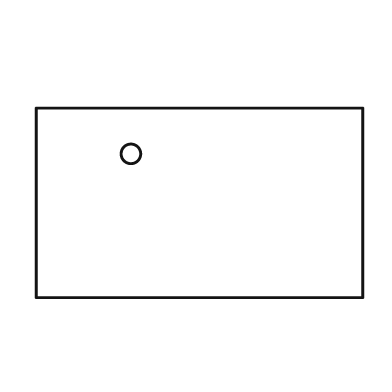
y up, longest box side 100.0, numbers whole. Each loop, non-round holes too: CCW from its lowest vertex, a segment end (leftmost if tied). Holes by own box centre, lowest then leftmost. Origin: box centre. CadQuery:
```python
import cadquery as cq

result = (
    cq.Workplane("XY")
    .moveTo(-50.0, -29.0)
    .lineTo(50.0, -29.0)
    .lineTo(50.0, 29.0)
    .lineTo(-50.0, 29.0)
    .close()
    .moveTo(-21.0, 15.0)
    .circle(3.0)
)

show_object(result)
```